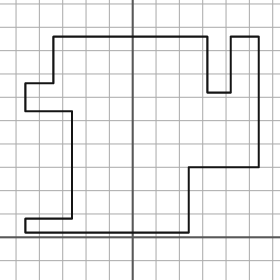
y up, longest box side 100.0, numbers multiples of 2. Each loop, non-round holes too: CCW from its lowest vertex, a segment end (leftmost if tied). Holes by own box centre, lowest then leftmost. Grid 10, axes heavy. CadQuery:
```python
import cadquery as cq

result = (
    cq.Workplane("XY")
    .moveTo(-46.0, 2.0)
    .lineTo(24.0, 2.0)
    .lineTo(24.0, 30.0)
    .lineTo(54.0, 30.0)
    .lineTo(54.0, 86.0)
    .lineTo(42.0, 86.0)
    .lineTo(42.0, 62.0)
    .lineTo(32.0, 62.0)
    .lineTo(32.0, 86.0)
    .lineTo(-34.0, 86.0)
    .lineTo(-34.0, 66.0)
    .lineTo(-46.0, 66.0)
    .lineTo(-46.0, 54.0)
    .lineTo(-26.0, 54.0)
    .lineTo(-26.0, 8.0)
    .lineTo(-46.0, 8.0)
    .close()
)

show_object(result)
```